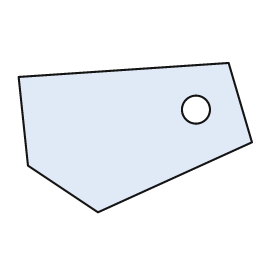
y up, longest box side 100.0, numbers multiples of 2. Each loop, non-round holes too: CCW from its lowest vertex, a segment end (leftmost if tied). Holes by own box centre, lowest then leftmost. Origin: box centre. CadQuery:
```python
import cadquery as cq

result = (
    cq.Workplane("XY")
    .moveTo(-16.0, -32.0)
    .lineTo(50.0, -2.0)
    .lineTo(40.0, 32.0)
    .lineTo(-50.0, 26.0)
    .lineTo(-46.0, -12.0)
    .close()
    .moveTo(26.0, 12.0)
    .circle(6.0)
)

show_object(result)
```